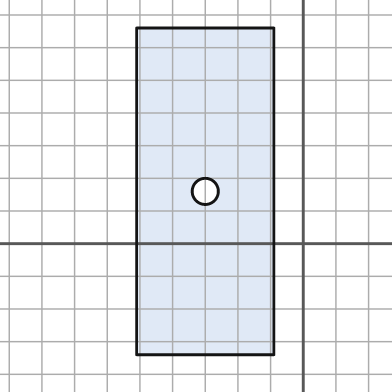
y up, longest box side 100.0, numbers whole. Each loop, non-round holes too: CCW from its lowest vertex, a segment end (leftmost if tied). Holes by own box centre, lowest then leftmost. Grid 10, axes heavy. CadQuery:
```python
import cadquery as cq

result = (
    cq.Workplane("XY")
    .moveTo(-51.0, -34.0)
    .lineTo(-9.0, -34.0)
    .lineTo(-9.0, 66.0)
    .lineTo(-51.0, 66.0)
    .close()
    .moveTo(-30.0, 16.0)
    .circle(4.0)
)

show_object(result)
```